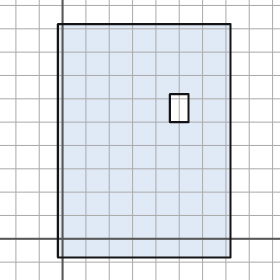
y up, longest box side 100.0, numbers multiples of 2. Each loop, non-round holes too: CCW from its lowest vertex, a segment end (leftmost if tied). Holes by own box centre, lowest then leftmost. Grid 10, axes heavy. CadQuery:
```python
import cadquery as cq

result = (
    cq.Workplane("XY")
    .moveTo(-2.0, -8.0)
    .lineTo(72.0, -8.0)
    .lineTo(72.0, 92.0)
    .lineTo(-2.0, 92.0)
    .close()
    .moveTo(46.0, 50.0)
    .lineTo(54.0, 50.0)
    .lineTo(54.0, 62.0)
    .lineTo(46.0, 62.0)
    .close()
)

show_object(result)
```